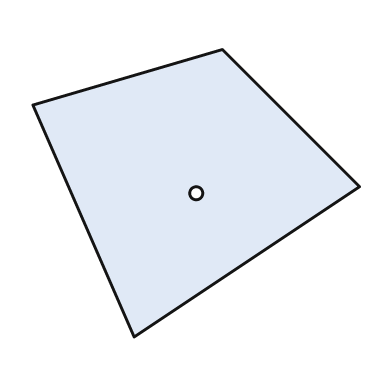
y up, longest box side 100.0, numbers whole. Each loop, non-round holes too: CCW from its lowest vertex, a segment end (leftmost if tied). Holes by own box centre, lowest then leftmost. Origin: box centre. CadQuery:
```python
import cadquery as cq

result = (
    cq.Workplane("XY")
    .moveTo(-19.0, -44.0)
    .lineTo(50.0, 2.0)
    .lineTo(8.0, 44.0)
    .lineTo(-50.0, 27.0)
    .close()
    .moveTo(0.0, 0.0)
    .circle(2.0)
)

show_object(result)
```